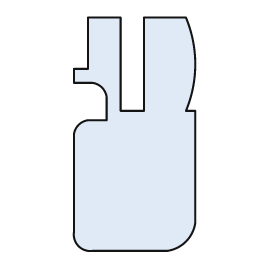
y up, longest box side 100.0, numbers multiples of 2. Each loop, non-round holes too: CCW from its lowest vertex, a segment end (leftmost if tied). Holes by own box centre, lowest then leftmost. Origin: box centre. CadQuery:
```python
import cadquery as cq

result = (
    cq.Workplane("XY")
    .moveTo(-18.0, -50.0)
    .lineTo(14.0, -50.0)
    .threePointArc((22.0, -46.0), (26.0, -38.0))
    .lineTo(26.0, 10.0)
    .lineTo(22.0, 10.0)
    .threePointArc((26.0, 30.0), (22.0, 50.0))
    .lineTo(4.0, 50.0)
    .lineTo(4.0, 10.0)
    .lineTo(-6.0, 10.0)
    .lineTo(-6.0, 50.0)
    .lineTo(-20.0, 50.0)
    .lineTo(-20.0, 28.0)
    .lineTo(-26.0, 28.0)
    .lineTo(-26.0, 22.0)
    .lineTo(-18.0, 22.0)
    .threePointArc((-14.0, 20.0), (-12.0, 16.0))
    .lineTo(-12.0, 6.0)
    .lineTo(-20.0, 6.0)
    .threePointArc((-24.0, 4.0), (-26.0, 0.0))
    .lineTo(-26.0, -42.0)
    .threePointArc((-24.0, -48.0), (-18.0, -50.0))
    .close()
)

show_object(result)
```